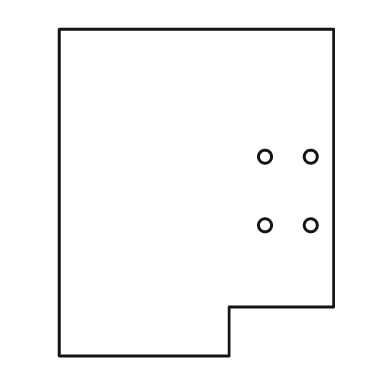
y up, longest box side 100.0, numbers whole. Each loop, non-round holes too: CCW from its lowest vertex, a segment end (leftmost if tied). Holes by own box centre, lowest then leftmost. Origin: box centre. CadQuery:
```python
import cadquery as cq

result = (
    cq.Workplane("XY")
    .moveTo(-42.0, -50.0)
    .lineTo(10.0, -50.0)
    .lineTo(10.0, -35.0)
    .lineTo(42.0, -35.0)
    .lineTo(42.0, 50.0)
    .lineTo(-42.0, 50.0)
    .close()
    .moveTo(21.0, -10.0)
    .circle(2.0)
    .moveTo(35.0, -10.0)
    .circle(2.0)
    .moveTo(21.0, 11.0)
    .circle(2.0)
    .moveTo(35.0, 11.0)
    .circle(2.0)
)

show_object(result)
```